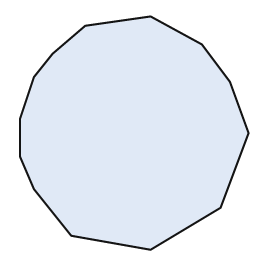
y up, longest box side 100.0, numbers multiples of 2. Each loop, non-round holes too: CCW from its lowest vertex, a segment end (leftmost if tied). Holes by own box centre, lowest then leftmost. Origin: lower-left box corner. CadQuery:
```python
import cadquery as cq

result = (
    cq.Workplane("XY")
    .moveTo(56.0, 0.0)
    .lineTo(86.0, 18.0)
    .lineTo(98.0, 50.0)
    .lineTo(90.0, 72.0)
    .lineTo(78.0, 88.0)
    .lineTo(56.0, 100.0)
    .lineTo(28.0, 96.0)
    .lineTo(14.0, 84.0)
    .lineTo(6.0, 74.0)
    .lineTo(0.0, 56.0)
    .lineTo(0.0, 40.0)
    .lineTo(6.0, 26.0)
    .lineTo(22.0, 6.0)
    .close()
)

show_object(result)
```